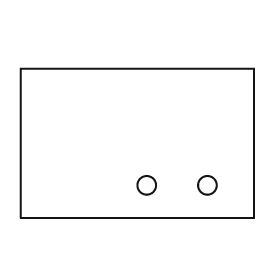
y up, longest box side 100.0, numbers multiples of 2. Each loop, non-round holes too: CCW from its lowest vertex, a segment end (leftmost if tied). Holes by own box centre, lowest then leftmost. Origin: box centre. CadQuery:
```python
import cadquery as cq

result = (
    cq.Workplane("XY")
    .moveTo(-50.0, -32.0)
    .lineTo(50.0, -32.0)
    .lineTo(50.0, 32.0)
    .lineTo(-50.0, 32.0)
    .close()
    .moveTo(4.0, -18.0)
    .circle(4.0)
    .moveTo(30.0, -18.0)
    .circle(4.0)
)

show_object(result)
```